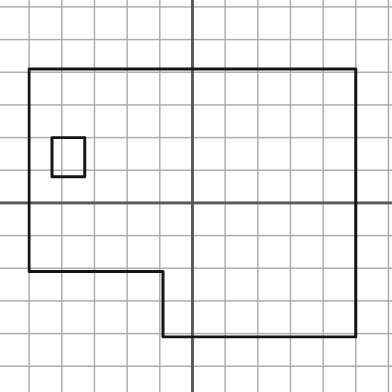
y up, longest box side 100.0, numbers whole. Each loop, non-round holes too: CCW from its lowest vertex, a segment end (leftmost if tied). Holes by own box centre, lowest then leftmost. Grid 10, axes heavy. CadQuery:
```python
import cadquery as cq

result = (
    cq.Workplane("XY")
    .moveTo(-9.0, -41.0)
    .lineTo(50.0, -41.0)
    .lineTo(50.0, 41.0)
    .lineTo(-50.0, 41.0)
    .lineTo(-50.0, -21.0)
    .lineTo(-9.0, -21.0)
    .close()
    .moveTo(-43.0, 8.0)
    .lineTo(-33.0, 8.0)
    .lineTo(-33.0, 20.0)
    .lineTo(-43.0, 20.0)
    .close()
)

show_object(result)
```